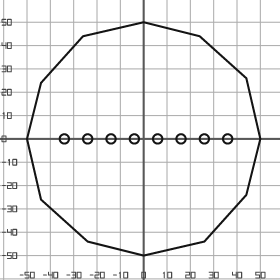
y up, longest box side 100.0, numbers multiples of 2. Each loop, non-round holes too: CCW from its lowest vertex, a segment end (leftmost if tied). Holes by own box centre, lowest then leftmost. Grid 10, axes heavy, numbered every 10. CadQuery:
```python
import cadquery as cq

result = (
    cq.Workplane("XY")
    .moveTo(0.0, -50.0)
    .lineTo(26.0, -44.0)
    .lineTo(44.0, -24.0)
    .lineTo(50.0, 0.0)
    .lineTo(44.0, 26.0)
    .lineTo(24.0, 44.0)
    .lineTo(0.0, 50.0)
    .lineTo(-26.0, 44.0)
    .lineTo(-44.0, 24.0)
    .lineTo(-50.0, 0.0)
    .lineTo(-44.0, -26.0)
    .lineTo(-24.0, -44.0)
    .close()
    .moveTo(-34.0, 0.0)
    .circle(2.0)
    .moveTo(-24.0, 0.0)
    .circle(2.0)
    .moveTo(-14.0, 0.0)
    .circle(2.0)
    .moveTo(-4.0, 0.0)
    .circle(2.0)
    .moveTo(6.0, 0.0)
    .circle(2.0)
    .moveTo(16.0, 0.0)
    .circle(2.0)
    .moveTo(26.0, 0.0)
    .circle(2.0)
    .moveTo(36.0, 0.0)
    .circle(2.0)
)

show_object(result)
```